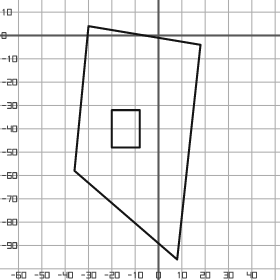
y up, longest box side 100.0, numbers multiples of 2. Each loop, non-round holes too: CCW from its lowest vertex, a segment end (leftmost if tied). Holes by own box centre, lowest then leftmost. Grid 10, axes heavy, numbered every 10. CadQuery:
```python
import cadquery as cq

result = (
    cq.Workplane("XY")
    .moveTo(8.0, -96.0)
    .lineTo(18.0, -4.0)
    .lineTo(-30.0, 4.0)
    .lineTo(-36.0, -58.0)
    .close()
    .moveTo(-20.0, -48.0)
    .lineTo(-8.0, -48.0)
    .lineTo(-8.0, -32.0)
    .lineTo(-20.0, -32.0)
    .close()
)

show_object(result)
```